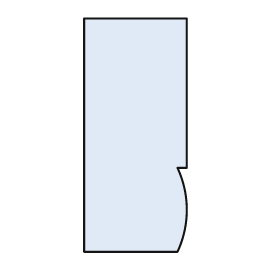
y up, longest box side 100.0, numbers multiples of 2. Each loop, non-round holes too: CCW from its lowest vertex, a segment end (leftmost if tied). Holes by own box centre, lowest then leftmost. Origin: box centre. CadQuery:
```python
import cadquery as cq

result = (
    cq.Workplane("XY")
    .moveTo(-22.0, -50.0)
    .lineTo(18.0, -50.0)
    .threePointArc((22.0, -32.0), (18.0, -14.0))
    .lineTo(22.0, -14.0)
    .lineTo(22.0, 50.0)
    .lineTo(-22.0, 50.0)
    .close()
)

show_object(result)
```